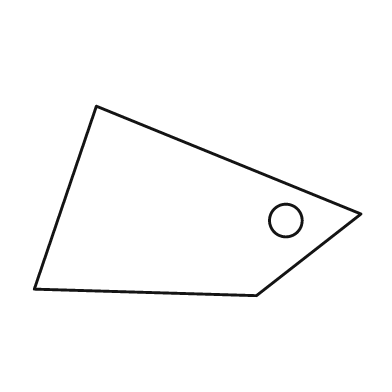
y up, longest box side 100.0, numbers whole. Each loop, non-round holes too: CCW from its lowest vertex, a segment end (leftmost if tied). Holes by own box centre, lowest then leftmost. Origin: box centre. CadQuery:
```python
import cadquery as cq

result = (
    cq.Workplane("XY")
    .moveTo(18.0, -29.0)
    .lineTo(50.0, -4.0)
    .lineTo(-31.0, 29.0)
    .lineTo(-50.0, -27.0)
    .close()
    .moveTo(27.0, -6.0)
    .circle(5.0)
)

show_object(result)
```